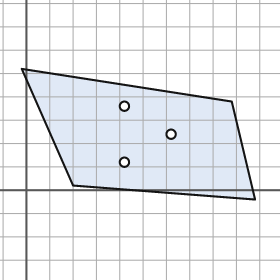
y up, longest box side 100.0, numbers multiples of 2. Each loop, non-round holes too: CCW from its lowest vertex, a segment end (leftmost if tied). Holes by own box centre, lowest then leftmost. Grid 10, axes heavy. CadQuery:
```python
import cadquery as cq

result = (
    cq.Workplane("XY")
    .moveTo(98.0, -4.0)
    .lineTo(88.0, 38.0)
    .lineTo(-2.0, 52.0)
    .lineTo(20.0, 2.0)
    .close()
    .moveTo(42.0, 12.0)
    .circle(2.0)
    .moveTo(62.0, 24.0)
    .circle(2.0)
    .moveTo(42.0, 36.0)
    .circle(2.0)
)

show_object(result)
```